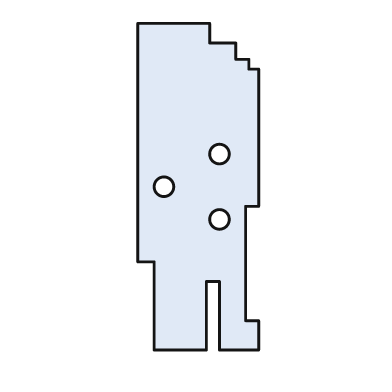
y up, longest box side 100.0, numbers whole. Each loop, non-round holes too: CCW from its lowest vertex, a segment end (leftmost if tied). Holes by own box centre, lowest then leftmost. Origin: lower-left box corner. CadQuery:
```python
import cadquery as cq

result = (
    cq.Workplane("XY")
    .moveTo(5.0, 0.0)
    .lineTo(21.0, 0.0)
    .lineTo(21.0, 21.0)
    .lineTo(25.0, 21.0)
    .lineTo(25.0, 0.0)
    .lineTo(37.0, 0.0)
    .lineTo(37.0, 9.0)
    .lineTo(33.0, 9.0)
    .lineTo(33.0, 44.0)
    .lineTo(37.0, 44.0)
    .lineTo(37.0, 86.0)
    .lineTo(34.0, 86.0)
    .lineTo(34.0, 89.0)
    .lineTo(30.0, 89.0)
    .lineTo(30.0, 94.0)
    .lineTo(22.0, 94.0)
    .lineTo(22.0, 100.0)
    .lineTo(0.0, 100.0)
    .lineTo(0.0, 27.0)
    .lineTo(5.0, 27.0)
    .close()
    .moveTo(25.0, 40.0)
    .circle(3.0)
    .moveTo(8.0, 50.0)
    .circle(3.0)
    .moveTo(25.0, 60.0)
    .circle(3.0)
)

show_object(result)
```